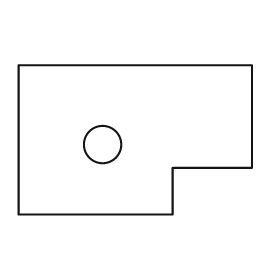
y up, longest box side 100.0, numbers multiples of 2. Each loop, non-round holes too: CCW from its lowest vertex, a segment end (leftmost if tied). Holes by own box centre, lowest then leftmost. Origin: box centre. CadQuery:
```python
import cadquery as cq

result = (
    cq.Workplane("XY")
    .moveTo(-50.0, -32.0)
    .lineTo(16.0, -32.0)
    .lineTo(16.0, -12.0)
    .lineTo(50.0, -12.0)
    .lineTo(50.0, 32.0)
    .lineTo(-50.0, 32.0)
    .close()
    .moveTo(-14.0, -2.0)
    .circle(8.0)
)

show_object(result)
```